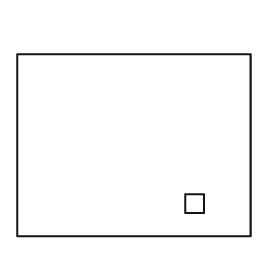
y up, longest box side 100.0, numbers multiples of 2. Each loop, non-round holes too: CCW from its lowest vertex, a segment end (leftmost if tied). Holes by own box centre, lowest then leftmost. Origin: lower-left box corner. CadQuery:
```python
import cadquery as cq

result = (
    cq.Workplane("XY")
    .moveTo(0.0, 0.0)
    .lineTo(100.0, 0.0)
    .lineTo(100.0, 78.0)
    .lineTo(0.0, 78.0)
    .close()
    .moveTo(72.0, 10.0)
    .lineTo(80.0, 10.0)
    .lineTo(80.0, 18.0)
    .lineTo(72.0, 18.0)
    .close()
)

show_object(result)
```